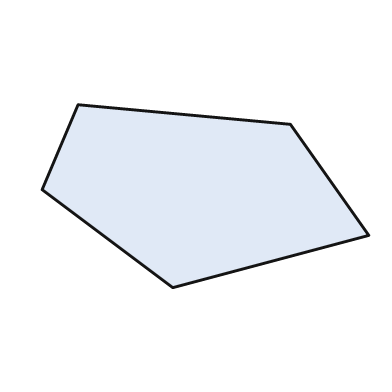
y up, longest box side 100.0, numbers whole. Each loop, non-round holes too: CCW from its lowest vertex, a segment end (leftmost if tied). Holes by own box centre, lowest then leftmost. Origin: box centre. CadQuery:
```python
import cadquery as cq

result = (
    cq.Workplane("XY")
    .moveTo(-10.0, -28.0)
    .lineTo(50.0, -12.0)
    .lineTo(26.0, 22.0)
    .lineTo(-39.0, 28.0)
    .lineTo(-50.0, 2.0)
    .close()
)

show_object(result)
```